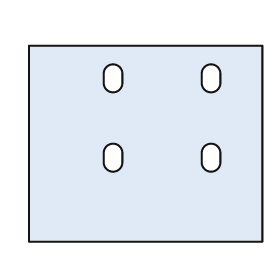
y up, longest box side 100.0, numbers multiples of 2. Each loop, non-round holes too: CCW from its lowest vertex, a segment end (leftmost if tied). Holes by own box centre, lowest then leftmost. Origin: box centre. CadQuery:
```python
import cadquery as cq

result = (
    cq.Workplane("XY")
    .moveTo(-50.0, -42.0)
    .lineTo(50.0, -42.0)
    .lineTo(50.0, 42.0)
    .lineTo(-50.0, 42.0)
    .close()
    .moveTo(-18.0, -8.0)
    .threePointArc((-14.0, -12.0), (-10.0, -8.0))
    .lineTo(-10.0, -4.0)
    .threePointArc((-14.0, 0.0), (-18.0, -4.0))
    .close()
    .moveTo(24.0, -8.0)
    .threePointArc((28.0, -12.0), (32.0, -8.0))
    .lineTo(32.0, -4.0)
    .threePointArc((28.0, 0.0), (24.0, -4.0))
    .close()
    .moveTo(-18.0, 26.0)
    .threePointArc((-14.0, 22.0), (-10.0, 26.0))
    .lineTo(-10.0, 30.0)
    .threePointArc((-14.0, 34.0), (-18.0, 30.0))
    .close()
    .moveTo(24.0, 26.0)
    .threePointArc((28.0, 22.0), (32.0, 26.0))
    .lineTo(32.0, 30.0)
    .threePointArc((28.0, 34.0), (24.0, 30.0))
    .close()
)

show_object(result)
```